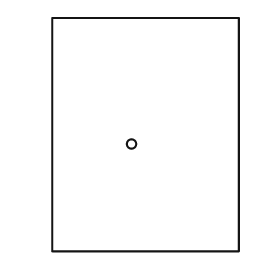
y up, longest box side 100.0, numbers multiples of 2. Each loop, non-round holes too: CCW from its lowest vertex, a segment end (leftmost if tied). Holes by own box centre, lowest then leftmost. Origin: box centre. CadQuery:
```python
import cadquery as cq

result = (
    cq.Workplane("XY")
    .moveTo(-40.0, -50.0)
    .lineTo(40.0, -50.0)
    .lineTo(40.0, 50.0)
    .lineTo(-40.0, 50.0)
    .close()
    .moveTo(-6.0, -4.0)
    .circle(2.0)
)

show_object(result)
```